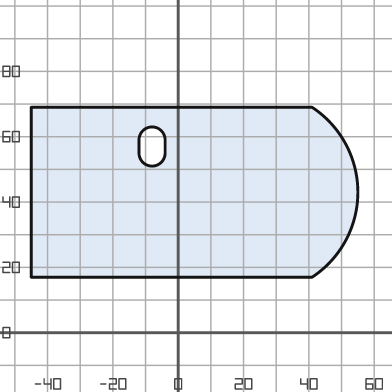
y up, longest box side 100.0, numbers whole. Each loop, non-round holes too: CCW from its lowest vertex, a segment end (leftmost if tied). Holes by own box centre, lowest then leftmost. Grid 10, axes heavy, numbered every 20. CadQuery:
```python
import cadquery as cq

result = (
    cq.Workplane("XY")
    .moveTo(-45.0, 17.0)
    .lineTo(41.0, 17.0)
    .threePointArc((55.0, 43.0), (41.0, 69.0))
    .lineTo(-45.0, 69.0)
    .close()
    .moveTo(-12.0, 55.0)
    .threePointArc((-8.0, 51.0), (-4.0, 55.0))
    .lineTo(-4.0, 59.0)
    .threePointArc((-8.0, 63.0), (-12.0, 59.0))
    .close()
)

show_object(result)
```